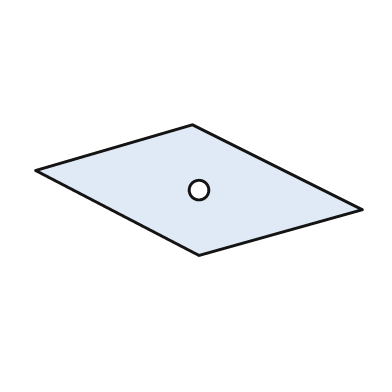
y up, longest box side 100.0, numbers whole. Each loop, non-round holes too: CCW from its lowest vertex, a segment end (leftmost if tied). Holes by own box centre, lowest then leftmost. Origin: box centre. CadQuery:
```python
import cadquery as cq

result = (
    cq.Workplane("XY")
    .moveTo(0.0, -20.0)
    .lineTo(50.0, -6.0)
    .lineTo(-2.0, 20.0)
    .lineTo(-50.0, 6.0)
    .close()
    .moveTo(0.0, 0.0)
    .circle(3.0)
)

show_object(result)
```